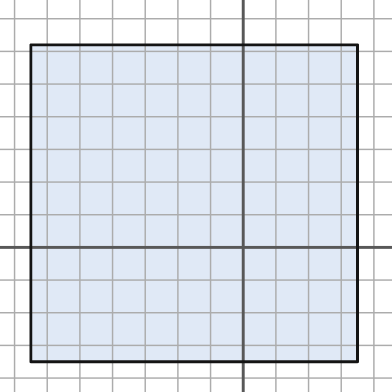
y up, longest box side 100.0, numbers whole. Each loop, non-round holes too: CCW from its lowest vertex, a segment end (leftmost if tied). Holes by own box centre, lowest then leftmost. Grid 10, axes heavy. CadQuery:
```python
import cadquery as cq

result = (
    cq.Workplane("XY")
    .moveTo(-65.0, -35.0)
    .lineTo(35.0, -35.0)
    .lineTo(35.0, 62.0)
    .lineTo(-65.0, 62.0)
    .close()
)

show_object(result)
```